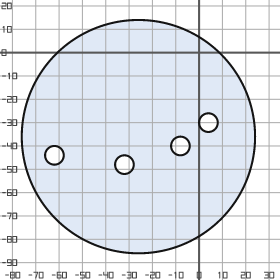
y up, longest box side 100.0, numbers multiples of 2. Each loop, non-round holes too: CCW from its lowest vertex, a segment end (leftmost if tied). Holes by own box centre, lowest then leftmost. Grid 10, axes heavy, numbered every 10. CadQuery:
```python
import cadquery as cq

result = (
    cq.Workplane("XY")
    .moveTo(-26.0, -36.0)
    .circle(50.0)
    .moveTo(-32.0, -48.0)
    .circle(4.0)
    .moveTo(-62.0, -44.0)
    .circle(4.0)
    .moveTo(-8.0, -40.0)
    .circle(4.0)
    .moveTo(4.0, -30.0)
    .circle(4.0)
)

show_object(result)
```